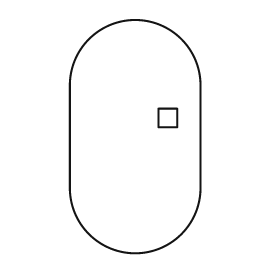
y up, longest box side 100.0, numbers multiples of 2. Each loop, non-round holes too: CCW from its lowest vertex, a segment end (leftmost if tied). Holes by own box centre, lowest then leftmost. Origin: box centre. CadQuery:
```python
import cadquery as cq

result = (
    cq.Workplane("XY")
    .moveTo(-28.0, -22.0)
    .threePointArc((0.0, -50.0), (28.0, -22.0))
    .lineTo(28.0, 22.0)
    .threePointArc((0.0, 50.0), (-28.0, 22.0))
    .close()
    .moveTo(10.0, 4.0)
    .lineTo(18.0, 4.0)
    .lineTo(18.0, 12.0)
    .lineTo(10.0, 12.0)
    .close()
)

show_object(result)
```